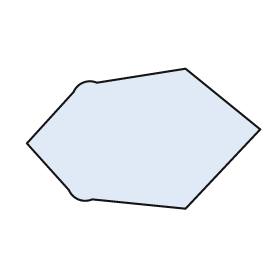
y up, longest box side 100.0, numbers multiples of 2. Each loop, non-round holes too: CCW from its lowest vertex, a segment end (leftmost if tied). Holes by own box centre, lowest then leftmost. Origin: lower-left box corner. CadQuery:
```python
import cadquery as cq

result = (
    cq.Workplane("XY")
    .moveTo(68.0, 0.0)
    .lineTo(100.0, 34.0)
    .lineTo(68.0, 60.0)
    .lineTo(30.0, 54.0)
    .threePointArc((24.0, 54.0), (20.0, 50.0))
    .lineTo(0.0, 28.0)
    .lineTo(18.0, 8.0)
    .threePointArc((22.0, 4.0), (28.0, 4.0))
    .close()
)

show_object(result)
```